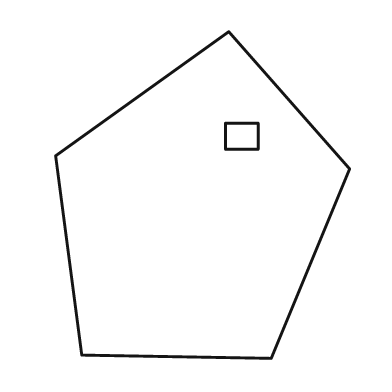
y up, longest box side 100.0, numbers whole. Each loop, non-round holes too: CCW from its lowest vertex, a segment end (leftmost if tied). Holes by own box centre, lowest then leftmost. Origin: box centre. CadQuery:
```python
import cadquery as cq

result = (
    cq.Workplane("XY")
    .moveTo(21.0, -50.0)
    .lineTo(45.0, 8.0)
    .lineTo(8.0, 50.0)
    .lineTo(-45.0, 12.0)
    .lineTo(-37.0, -49.0)
    .close()
    .moveTo(7.0, 14.0)
    .lineTo(17.0, 14.0)
    .lineTo(17.0, 22.0)
    .lineTo(7.0, 22.0)
    .close()
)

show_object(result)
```